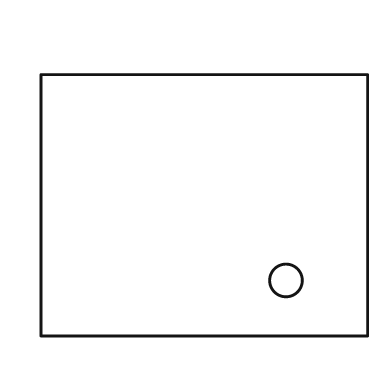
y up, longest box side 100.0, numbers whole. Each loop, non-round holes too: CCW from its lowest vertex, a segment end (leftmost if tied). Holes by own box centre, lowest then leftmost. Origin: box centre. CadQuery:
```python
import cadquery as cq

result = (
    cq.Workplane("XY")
    .moveTo(-50.0, -40.0)
    .lineTo(50.0, -40.0)
    .lineTo(50.0, 40.0)
    .lineTo(-50.0, 40.0)
    .close()
    .moveTo(25.0, -23.0)
    .circle(5.0)
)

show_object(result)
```